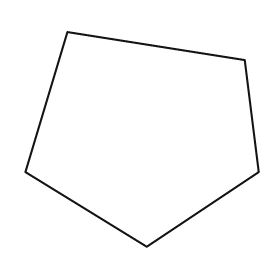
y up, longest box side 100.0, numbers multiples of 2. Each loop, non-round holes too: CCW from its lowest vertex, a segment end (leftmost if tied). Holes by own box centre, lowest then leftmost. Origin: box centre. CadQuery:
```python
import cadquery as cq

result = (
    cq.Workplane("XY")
    .moveTo(2.0, -46.0)
    .lineTo(50.0, -14.0)
    .lineTo(44.0, 34.0)
    .lineTo(-32.0, 46.0)
    .lineTo(-50.0, -14.0)
    .close()
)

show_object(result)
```